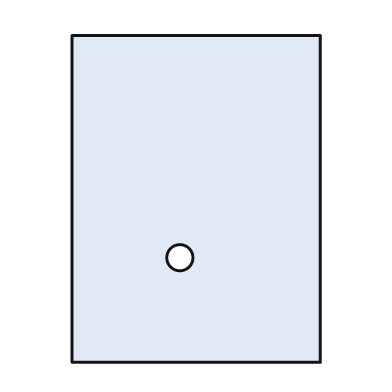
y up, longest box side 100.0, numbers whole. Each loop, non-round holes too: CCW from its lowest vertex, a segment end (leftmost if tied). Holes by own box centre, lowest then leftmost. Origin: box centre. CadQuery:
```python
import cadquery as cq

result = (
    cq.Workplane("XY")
    .moveTo(-38.0, -50.0)
    .lineTo(38.0, -50.0)
    .lineTo(38.0, 50.0)
    .lineTo(-38.0, 50.0)
    .close()
    .moveTo(-5.0, -18.0)
    .circle(4.0)
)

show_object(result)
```